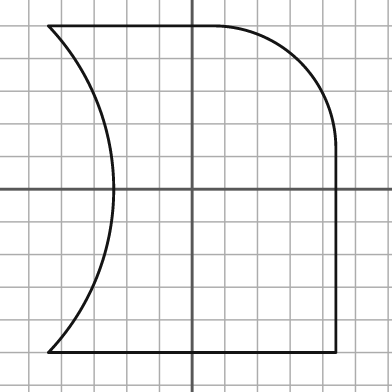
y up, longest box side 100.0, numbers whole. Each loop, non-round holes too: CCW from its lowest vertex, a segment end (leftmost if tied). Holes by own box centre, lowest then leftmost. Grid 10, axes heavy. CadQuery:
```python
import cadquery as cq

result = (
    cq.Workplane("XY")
    .moveTo(-44.0, -50.0)
    .lineTo(44.0, -50.0)
    .lineTo(44.0, 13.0)
    .threePointArc((33.0, 39.0), (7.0, 50.0))
    .lineTo(-44.0, 50.0)
    .threePointArc((-24.0, 0.0), (-44.0, -50.0))
    .close()
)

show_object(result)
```